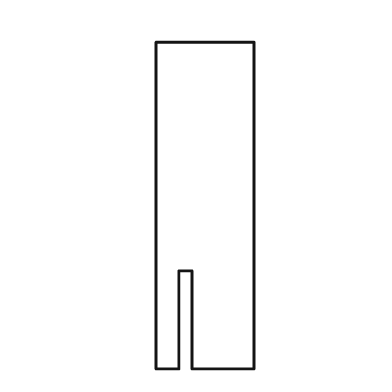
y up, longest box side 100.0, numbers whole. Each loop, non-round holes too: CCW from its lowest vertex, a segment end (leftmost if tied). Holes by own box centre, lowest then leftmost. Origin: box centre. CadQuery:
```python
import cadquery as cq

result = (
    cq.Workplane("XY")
    .moveTo(-15.0, -50.0)
    .lineTo(-8.0, -50.0)
    .lineTo(-8.0, -20.0)
    .lineTo(-4.0, -20.0)
    .lineTo(-4.0, -50.0)
    .lineTo(15.0, -50.0)
    .lineTo(15.0, 50.0)
    .lineTo(-15.0, 50.0)
    .close()
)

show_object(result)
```